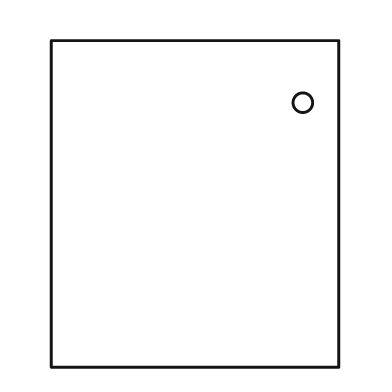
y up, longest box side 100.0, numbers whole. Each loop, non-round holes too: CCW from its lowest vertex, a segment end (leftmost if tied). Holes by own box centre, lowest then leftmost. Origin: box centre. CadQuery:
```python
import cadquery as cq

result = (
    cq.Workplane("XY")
    .moveTo(-44.0, -50.0)
    .lineTo(44.0, -50.0)
    .lineTo(44.0, 50.0)
    .lineTo(-44.0, 50.0)
    .close()
    .moveTo(33.0, 31.0)
    .circle(3.0)
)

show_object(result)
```